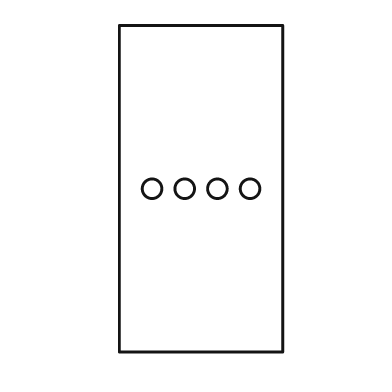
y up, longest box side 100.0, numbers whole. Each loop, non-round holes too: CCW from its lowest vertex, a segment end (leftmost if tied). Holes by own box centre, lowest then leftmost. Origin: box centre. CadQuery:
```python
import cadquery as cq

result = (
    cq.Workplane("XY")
    .moveTo(-25.0, -50.0)
    .lineTo(25.0, -50.0)
    .lineTo(25.0, 50.0)
    .lineTo(-25.0, 50.0)
    .close()
    .moveTo(-15.0, 0.0)
    .circle(3.0)
    .moveTo(-5.0, 0.0)
    .circle(3.0)
    .moveTo(5.0, 0.0)
    .circle(3.0)
    .moveTo(15.0, 0.0)
    .circle(3.0)
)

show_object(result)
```